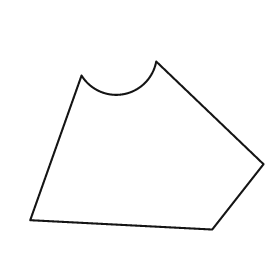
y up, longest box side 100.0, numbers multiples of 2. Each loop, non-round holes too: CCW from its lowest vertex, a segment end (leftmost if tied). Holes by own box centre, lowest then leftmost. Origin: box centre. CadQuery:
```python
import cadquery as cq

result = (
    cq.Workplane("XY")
    .moveTo(28.0, -36.0)
    .lineTo(50.0, -8.0)
    .lineTo(4.0, 36.0)
    .threePointArc((-10.0, 22.0), (-28.0, 30.0))
    .lineTo(-50.0, -32.0)
    .close()
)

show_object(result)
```